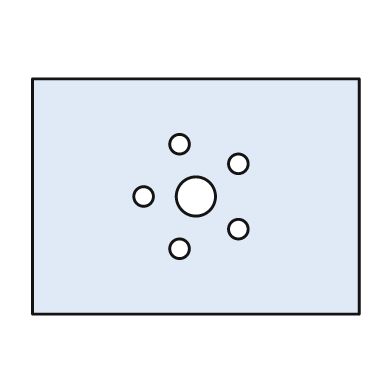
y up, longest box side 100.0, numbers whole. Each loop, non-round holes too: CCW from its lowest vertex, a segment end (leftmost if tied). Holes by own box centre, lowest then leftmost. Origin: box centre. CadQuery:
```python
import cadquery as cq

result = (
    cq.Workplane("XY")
    .moveTo(-50.0, -36.0)
    .lineTo(50.0, -36.0)
    .lineTo(50.0, 36.0)
    .lineTo(-50.0, 36.0)
    .close()
    .moveTo(-5.0, -16.0)
    .circle(3.0)
    .moveTo(13.0, -10.0)
    .circle(3.0)
    .moveTo(-16.0, 0.0)
    .circle(3.0)
    .moveTo(0.0, 0.0)
    .circle(6.0)
    .moveTo(13.0, 10.0)
    .circle(3.0)
    .moveTo(-5.0, 16.0)
    .circle(3.0)
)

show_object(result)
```